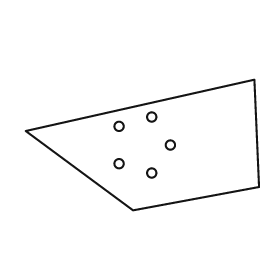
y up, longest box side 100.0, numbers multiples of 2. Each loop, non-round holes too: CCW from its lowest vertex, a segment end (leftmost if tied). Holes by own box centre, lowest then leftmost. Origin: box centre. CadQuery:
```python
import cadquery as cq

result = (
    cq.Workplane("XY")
    .moveTo(-4.0, -28.0)
    .lineTo(50.0, -18.0)
    .lineTo(48.0, 28.0)
    .lineTo(-50.0, 6.0)
    .close()
    .moveTo(4.0, -12.0)
    .circle(2.0)
    .moveTo(-10.0, -8.0)
    .circle(2.0)
    .moveTo(12.0, 0.0)
    .circle(2.0)
    .moveTo(-10.0, 8.0)
    .circle(2.0)
    .moveTo(4.0, 12.0)
    .circle(2.0)
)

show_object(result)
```